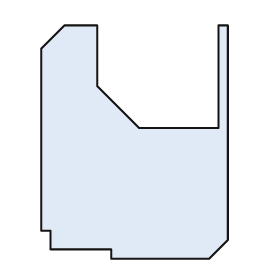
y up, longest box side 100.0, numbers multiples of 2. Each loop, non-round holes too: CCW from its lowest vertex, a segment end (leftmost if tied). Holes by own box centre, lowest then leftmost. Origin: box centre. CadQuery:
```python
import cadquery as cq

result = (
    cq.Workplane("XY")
    .moveTo(-10.0, -50.0)
    .lineTo(32.0, -50.0)
    .lineTo(40.0, -42.0)
    .lineTo(40.0, 50.0)
    .lineTo(36.0, 50.0)
    .lineTo(36.0, 6.0)
    .lineTo(2.0, 6.0)
    .lineTo(-16.0, 24.0)
    .lineTo(-16.0, 50.0)
    .lineTo(-30.0, 50.0)
    .lineTo(-40.0, 40.0)
    .lineTo(-40.0, -38.0)
    .lineTo(-36.0, -38.0)
    .lineTo(-36.0, -46.0)
    .lineTo(-10.0, -46.0)
    .close()
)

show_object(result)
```